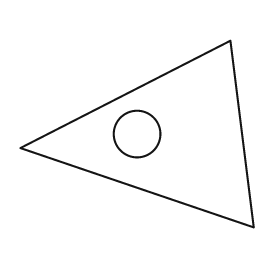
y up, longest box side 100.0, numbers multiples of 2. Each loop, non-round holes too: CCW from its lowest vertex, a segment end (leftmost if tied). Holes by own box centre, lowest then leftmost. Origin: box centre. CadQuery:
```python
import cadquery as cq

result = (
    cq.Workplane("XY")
    .moveTo(50.0, -40.0)
    .lineTo(40.0, 40.0)
    .lineTo(-50.0, -6.0)
    .close()
    .moveTo(0.0, 0.0)
    .circle(10.0)
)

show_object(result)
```